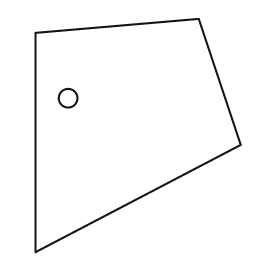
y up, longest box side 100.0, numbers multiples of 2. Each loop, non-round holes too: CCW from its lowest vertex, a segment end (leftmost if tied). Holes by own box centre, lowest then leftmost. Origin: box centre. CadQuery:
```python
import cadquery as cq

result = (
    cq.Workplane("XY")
    .moveTo(-44.0, -50.0)
    .lineTo(44.0, -4.0)
    .lineTo(26.0, 50.0)
    .lineTo(-44.0, 44.0)
    .close()
    .moveTo(-30.0, 16.0)
    .circle(4.0)
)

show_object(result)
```